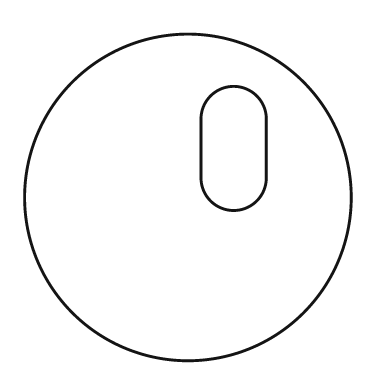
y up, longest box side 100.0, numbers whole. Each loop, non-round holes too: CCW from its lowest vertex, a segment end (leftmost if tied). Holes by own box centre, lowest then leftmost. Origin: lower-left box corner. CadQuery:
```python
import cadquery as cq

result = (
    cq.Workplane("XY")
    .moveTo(50.0, 50.0)
    .circle(50.0)
    .moveTo(54.0, 56.0)
    .threePointArc((64.0, 46.0), (74.0, 56.0))
    .lineTo(74.0, 74.0)
    .threePointArc((64.0, 84.0), (54.0, 74.0))
    .close()
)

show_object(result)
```